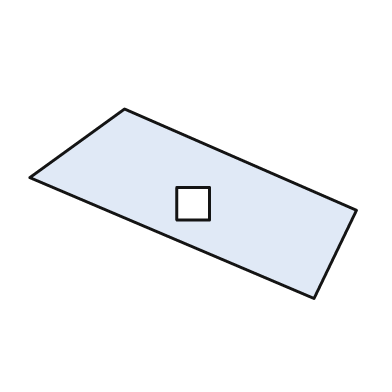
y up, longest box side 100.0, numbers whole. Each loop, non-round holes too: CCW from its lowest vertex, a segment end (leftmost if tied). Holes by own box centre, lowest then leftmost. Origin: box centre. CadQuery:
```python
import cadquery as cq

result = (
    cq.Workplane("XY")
    .moveTo(37.0, -29.0)
    .lineTo(50.0, -2.0)
    .lineTo(-21.0, 29.0)
    .lineTo(-50.0, 8.0)
    .close()
    .moveTo(-5.0, -5.0)
    .lineTo(5.0, -5.0)
    .lineTo(5.0, 5.0)
    .lineTo(-5.0, 5.0)
    .close()
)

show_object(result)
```